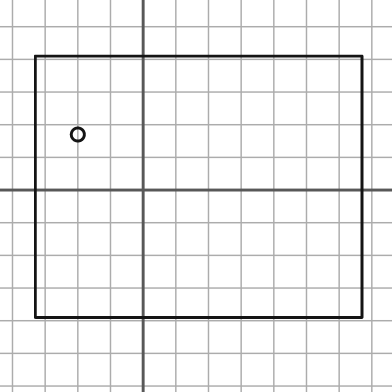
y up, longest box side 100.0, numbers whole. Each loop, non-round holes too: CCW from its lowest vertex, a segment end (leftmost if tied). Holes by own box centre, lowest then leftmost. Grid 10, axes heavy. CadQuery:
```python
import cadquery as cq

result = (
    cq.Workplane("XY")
    .moveTo(-33.0, -39.0)
    .lineTo(67.0, -39.0)
    .lineTo(67.0, 41.0)
    .lineTo(-33.0, 41.0)
    .close()
    .moveTo(-20.0, 17.0)
    .circle(2.0)
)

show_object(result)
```